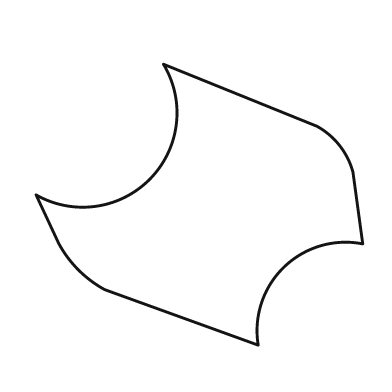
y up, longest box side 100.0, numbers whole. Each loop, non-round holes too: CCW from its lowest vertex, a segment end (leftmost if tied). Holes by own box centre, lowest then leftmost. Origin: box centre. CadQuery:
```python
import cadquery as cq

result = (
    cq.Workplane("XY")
    .moveTo(18.0, -43.0)
    .threePointArc((26.0, -19.0), (50.0, -12.0))
    .lineTo(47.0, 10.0)
    .threePointArc((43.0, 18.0), (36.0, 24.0))
    .lineTo(-11.0, 43.0)
    .threePointArc((-15.0, 8.0), (-50.0, 3.0))
    .lineTo(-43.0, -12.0)
    .threePointArc((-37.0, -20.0), (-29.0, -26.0))
    .close()
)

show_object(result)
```